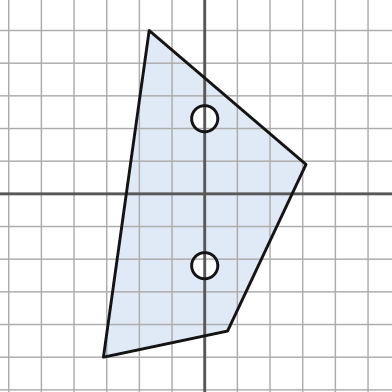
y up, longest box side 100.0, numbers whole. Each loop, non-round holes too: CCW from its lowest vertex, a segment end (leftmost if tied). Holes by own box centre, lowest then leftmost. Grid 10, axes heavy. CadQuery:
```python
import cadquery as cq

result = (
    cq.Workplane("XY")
    .moveTo(-31.0, -50.0)
    .lineTo(7.0, -42.0)
    .lineTo(31.0, 9.0)
    .lineTo(-17.0, 50.0)
    .close()
    .moveTo(0.0, -22.0)
    .circle(4.0)
    .moveTo(0.0, 23.0)
    .circle(4.0)
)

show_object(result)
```